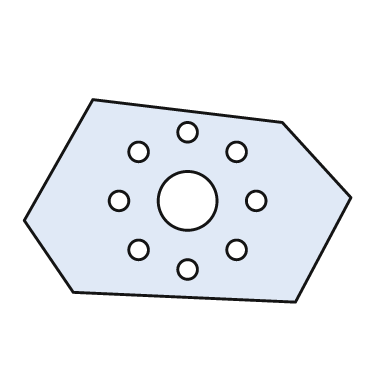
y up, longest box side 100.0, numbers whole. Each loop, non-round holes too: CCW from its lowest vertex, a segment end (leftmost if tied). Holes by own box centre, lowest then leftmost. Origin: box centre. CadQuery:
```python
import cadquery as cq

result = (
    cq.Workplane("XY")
    .moveTo(33.0, -31.0)
    .lineTo(50.0, 1.0)
    .lineTo(29.0, 24.0)
    .lineTo(-29.0, 31.0)
    .lineTo(-50.0, -6.0)
    .lineTo(-35.0, -28.0)
    .close()
    .moveTo(0.0, -21.0)
    .circle(3.0)
    .moveTo(-15.0, -15.0)
    .circle(3.0)
    .moveTo(15.0, -15.0)
    .circle(3.0)
    .moveTo(-21.0, 0.0)
    .circle(3.0)
    .moveTo(0.0, 0.0)
    .circle(9.0)
    .moveTo(21.0, 0.0)
    .circle(3.0)
    .moveTo(-15.0, 15.0)
    .circle(3.0)
    .moveTo(15.0, 15.0)
    .circle(3.0)
    .moveTo(0.0, 21.0)
    .circle(3.0)
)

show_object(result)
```